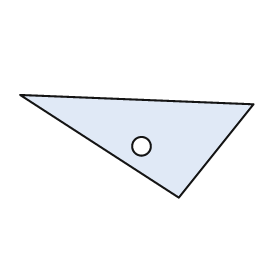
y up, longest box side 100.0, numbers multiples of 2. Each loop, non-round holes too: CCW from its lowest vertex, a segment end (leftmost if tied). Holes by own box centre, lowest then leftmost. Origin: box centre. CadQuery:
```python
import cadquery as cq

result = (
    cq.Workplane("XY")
    .moveTo(18.0, -22.0)
    .lineTo(50.0, 18.0)
    .lineTo(-50.0, 22.0)
    .close()
    .moveTo(2.0, 0.0)
    .circle(4.0)
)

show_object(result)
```